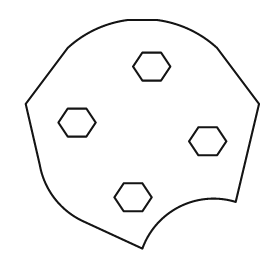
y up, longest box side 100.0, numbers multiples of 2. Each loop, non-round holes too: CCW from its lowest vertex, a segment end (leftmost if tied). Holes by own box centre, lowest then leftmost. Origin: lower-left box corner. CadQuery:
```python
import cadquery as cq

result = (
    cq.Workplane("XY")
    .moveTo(50.0, 0.0)
    .threePointArc((66.0, 18.0), (90.0, 20.0))
    .lineTo(100.0, 62.0)
    .lineTo(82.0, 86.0)
    .threePointArc((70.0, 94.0), (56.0, 98.0))
    .lineTo(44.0, 98.0)
    .threePointArc((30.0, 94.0), (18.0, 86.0))
    .lineTo(0.0, 62.0)
    .lineTo(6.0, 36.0)
    .threePointArc((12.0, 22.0), (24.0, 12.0))
    .close()
    .moveTo(42.0, 16.0)
    .lineTo(50.0, 16.0)
    .lineTo(54.0, 22.0)
    .lineTo(50.0, 28.0)
    .lineTo(42.0, 28.0)
    .lineTo(38.0, 22.0)
    .close()
    .moveTo(74.0, 40.0)
    .lineTo(82.0, 40.0)
    .lineTo(86.0, 46.0)
    .lineTo(82.0, 52.0)
    .lineTo(74.0, 52.0)
    .lineTo(70.0, 46.0)
    .close()
    .moveTo(18.0, 48.0)
    .lineTo(26.0, 48.0)
    .lineTo(30.0, 54.0)
    .lineTo(26.0, 60.0)
    .lineTo(18.0, 60.0)
    .lineTo(14.0, 54.0)
    .close()
    .moveTo(50.0, 72.0)
    .lineTo(58.0, 72.0)
    .lineTo(62.0, 78.0)
    .lineTo(58.0, 84.0)
    .lineTo(50.0, 84.0)
    .lineTo(46.0, 78.0)
    .close()
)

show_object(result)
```